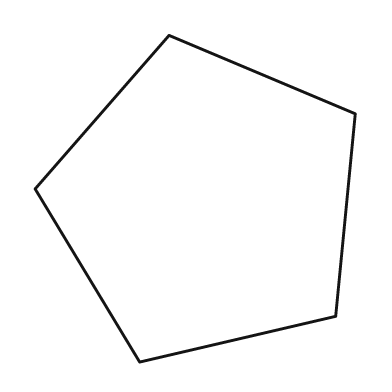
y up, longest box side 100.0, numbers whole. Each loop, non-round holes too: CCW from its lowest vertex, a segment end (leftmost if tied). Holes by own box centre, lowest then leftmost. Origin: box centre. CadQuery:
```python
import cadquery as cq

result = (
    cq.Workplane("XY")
    .moveTo(-17.0, -50.0)
    .lineTo(43.0, -36.0)
    .lineTo(49.0, 26.0)
    .lineTo(-8.0, 50.0)
    .lineTo(-49.0, 3.0)
    .close()
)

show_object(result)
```